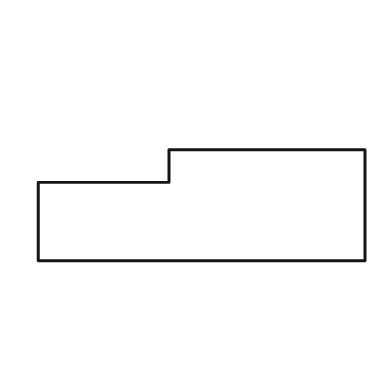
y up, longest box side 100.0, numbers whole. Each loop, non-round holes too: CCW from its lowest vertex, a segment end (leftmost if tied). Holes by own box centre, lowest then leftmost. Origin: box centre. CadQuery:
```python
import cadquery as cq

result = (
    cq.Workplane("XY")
    .moveTo(-50.0, -17.0)
    .lineTo(50.0, -17.0)
    .lineTo(50.0, 17.0)
    .lineTo(-10.0, 17.0)
    .lineTo(-10.0, 7.0)
    .lineTo(-50.0, 7.0)
    .close()
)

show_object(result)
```